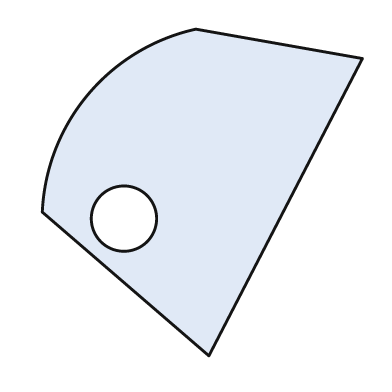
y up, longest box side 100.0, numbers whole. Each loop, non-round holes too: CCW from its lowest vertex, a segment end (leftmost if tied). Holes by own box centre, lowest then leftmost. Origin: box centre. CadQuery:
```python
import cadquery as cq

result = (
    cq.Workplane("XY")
    .moveTo(2.0, -50.0)
    .lineTo(49.0, 41.0)
    .lineTo(-2.0, 50.0)
    .threePointArc((-35.0, 30.0), (-49.0, -6.0))
    .close()
    .moveTo(-24.0, -8.0)
    .circle(10.0)
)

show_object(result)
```